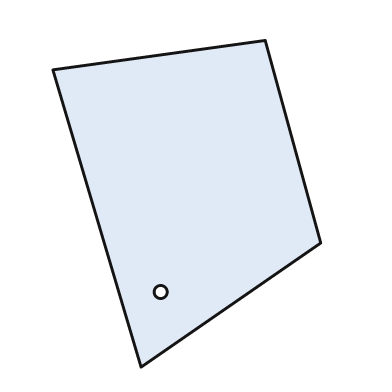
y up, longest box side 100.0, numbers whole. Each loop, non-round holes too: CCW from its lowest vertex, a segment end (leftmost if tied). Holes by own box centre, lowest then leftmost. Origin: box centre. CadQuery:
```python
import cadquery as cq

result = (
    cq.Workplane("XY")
    .moveTo(-14.0, -50.0)
    .lineTo(41.0, -12.0)
    .lineTo(24.0, 50.0)
    .lineTo(-41.0, 41.0)
    .close()
    .moveTo(-8.0, -27.0)
    .circle(2.0)
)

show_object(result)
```